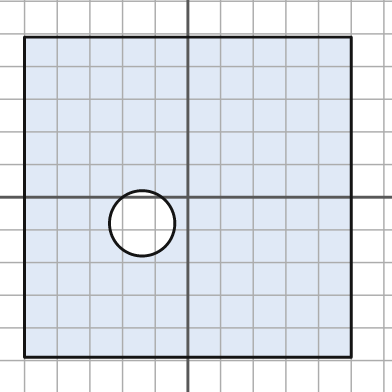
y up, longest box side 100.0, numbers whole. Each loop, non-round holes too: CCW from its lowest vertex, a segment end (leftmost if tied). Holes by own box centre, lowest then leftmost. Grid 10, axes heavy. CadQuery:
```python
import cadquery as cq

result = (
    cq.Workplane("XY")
    .moveTo(-50.0, -49.0)
    .lineTo(50.0, -49.0)
    .lineTo(50.0, 49.0)
    .lineTo(-50.0, 49.0)
    .close()
    .moveTo(-14.0, -8.0)
    .circle(10.0)
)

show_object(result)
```